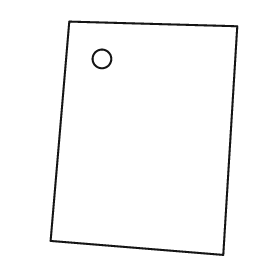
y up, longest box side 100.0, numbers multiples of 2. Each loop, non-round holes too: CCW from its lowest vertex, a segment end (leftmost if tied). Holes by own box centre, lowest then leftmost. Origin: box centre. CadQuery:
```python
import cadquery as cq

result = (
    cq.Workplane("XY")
    .moveTo(34.0, -50.0)
    .lineTo(40.0, 48.0)
    .lineTo(-32.0, 50.0)
    .lineTo(-40.0, -44.0)
    .close()
    .moveTo(-18.0, 34.0)
    .circle(4.0)
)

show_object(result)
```